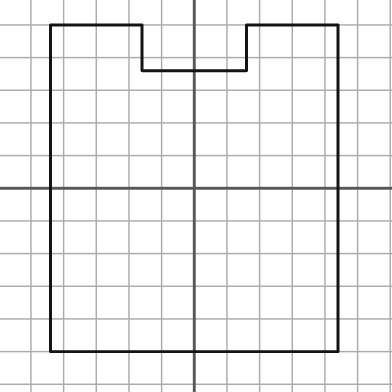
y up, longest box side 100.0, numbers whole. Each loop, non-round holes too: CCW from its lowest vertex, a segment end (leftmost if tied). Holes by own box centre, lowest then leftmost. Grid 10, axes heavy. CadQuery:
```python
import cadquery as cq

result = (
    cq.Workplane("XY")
    .moveTo(-44.0, -50.0)
    .lineTo(44.0, -50.0)
    .lineTo(44.0, 50.0)
    .lineTo(16.0, 50.0)
    .lineTo(16.0, 36.0)
    .lineTo(-16.0, 36.0)
    .lineTo(-16.0, 50.0)
    .lineTo(-44.0, 50.0)
    .close()
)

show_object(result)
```